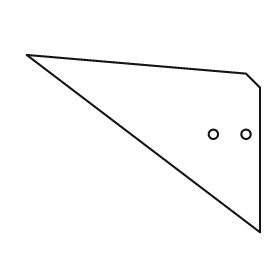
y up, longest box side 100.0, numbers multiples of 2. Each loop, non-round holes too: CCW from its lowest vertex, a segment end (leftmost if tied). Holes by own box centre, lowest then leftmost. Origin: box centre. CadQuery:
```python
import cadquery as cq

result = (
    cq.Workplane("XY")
    .moveTo(50.0, -38.0)
    .lineTo(50.0, 24.0)
    .lineTo(44.0, 30.0)
    .lineTo(-50.0, 38.0)
    .close()
    .moveTo(30.0, 4.0)
    .circle(2.0)
    .moveTo(44.0, 4.0)
    .circle(2.0)
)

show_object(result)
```